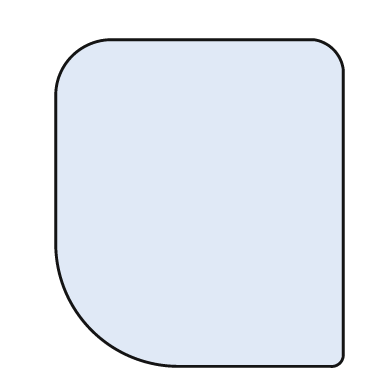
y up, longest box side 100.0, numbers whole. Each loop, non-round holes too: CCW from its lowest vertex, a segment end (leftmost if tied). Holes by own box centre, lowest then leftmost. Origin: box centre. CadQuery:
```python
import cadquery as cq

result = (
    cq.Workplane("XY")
    .moveTo(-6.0, -50.0)
    .lineTo(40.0, -50.0)
    .threePointArc((43.0, -49.0), (44.0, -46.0))
    .lineTo(44.0, 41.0)
    .threePointArc((41.0, 47.0), (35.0, 50.0))
    .lineTo(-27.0, 50.0)
    .threePointArc((-39.0, 45.0), (-44.0, 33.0))
    .lineTo(-44.0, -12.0)
    .threePointArc((-33.0, -39.0), (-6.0, -50.0))
    .close()
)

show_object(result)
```